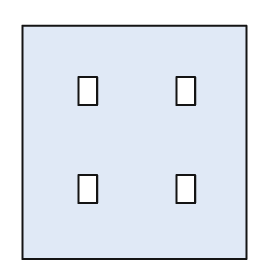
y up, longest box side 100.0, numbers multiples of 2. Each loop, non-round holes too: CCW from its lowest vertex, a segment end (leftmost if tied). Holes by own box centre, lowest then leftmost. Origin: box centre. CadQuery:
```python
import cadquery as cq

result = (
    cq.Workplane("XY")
    .moveTo(-48.0, -50.0)
    .lineTo(48.0, -50.0)
    .lineTo(48.0, 50.0)
    .lineTo(-48.0, 50.0)
    .close()
    .moveTo(-24.0, -26.0)
    .lineTo(-16.0, -26.0)
    .lineTo(-16.0, -14.0)
    .lineTo(-24.0, -14.0)
    .close()
    .moveTo(18.0, -26.0)
    .lineTo(26.0, -26.0)
    .lineTo(26.0, -14.0)
    .lineTo(18.0, -14.0)
    .close()
    .moveTo(-24.0, 16.0)
    .lineTo(-16.0, 16.0)
    .lineTo(-16.0, 28.0)
    .lineTo(-24.0, 28.0)
    .close()
    .moveTo(18.0, 16.0)
    .lineTo(26.0, 16.0)
    .lineTo(26.0, 28.0)
    .lineTo(18.0, 28.0)
    .close()
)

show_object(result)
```